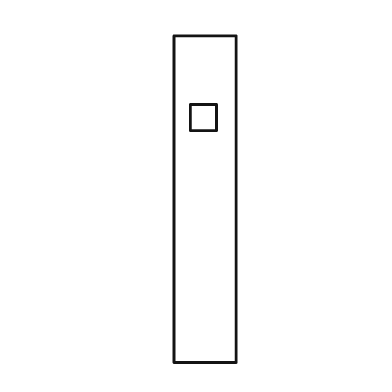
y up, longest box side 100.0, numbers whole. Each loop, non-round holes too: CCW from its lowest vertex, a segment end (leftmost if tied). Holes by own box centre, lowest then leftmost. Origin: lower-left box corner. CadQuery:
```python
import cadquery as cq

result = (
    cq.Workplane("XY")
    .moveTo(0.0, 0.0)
    .lineTo(19.0, 0.0)
    .lineTo(19.0, 100.0)
    .lineTo(0.0, 100.0)
    .close()
    .moveTo(5.0, 71.0)
    .lineTo(13.0, 71.0)
    .lineTo(13.0, 79.0)
    .lineTo(5.0, 79.0)
    .close()
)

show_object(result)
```